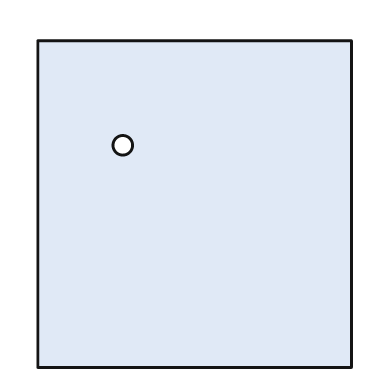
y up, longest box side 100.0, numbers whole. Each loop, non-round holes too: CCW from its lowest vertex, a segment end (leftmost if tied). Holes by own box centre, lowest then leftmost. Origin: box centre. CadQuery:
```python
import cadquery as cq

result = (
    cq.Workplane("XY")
    .moveTo(-48.0, -50.0)
    .lineTo(48.0, -50.0)
    .lineTo(48.0, 50.0)
    .lineTo(-48.0, 50.0)
    .close()
    .moveTo(-22.0, 18.0)
    .circle(3.0)
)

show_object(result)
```